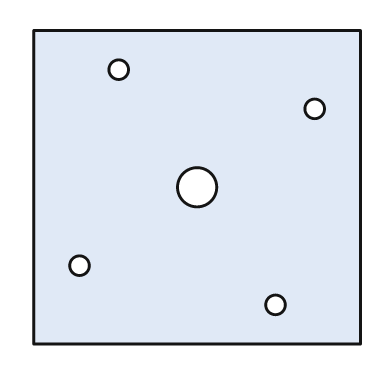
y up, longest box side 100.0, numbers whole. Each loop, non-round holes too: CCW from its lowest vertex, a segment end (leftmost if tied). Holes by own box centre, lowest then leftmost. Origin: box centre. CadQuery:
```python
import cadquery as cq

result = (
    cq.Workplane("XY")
    .moveTo(-50.0, -48.0)
    .lineTo(50.0, -48.0)
    .lineTo(50.0, 48.0)
    .lineTo(-50.0, 48.0)
    .close()
    .moveTo(24.0, -36.0)
    .circle(3.0)
    .moveTo(-36.0, -24.0)
    .circle(3.0)
    .moveTo(0.0, 0.0)
    .circle(6.0)
    .moveTo(36.0, 24.0)
    .circle(3.0)
    .moveTo(-24.0, 36.0)
    .circle(3.0)
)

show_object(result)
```